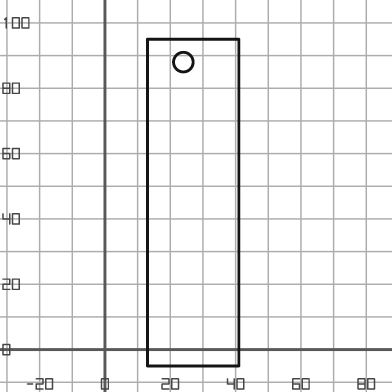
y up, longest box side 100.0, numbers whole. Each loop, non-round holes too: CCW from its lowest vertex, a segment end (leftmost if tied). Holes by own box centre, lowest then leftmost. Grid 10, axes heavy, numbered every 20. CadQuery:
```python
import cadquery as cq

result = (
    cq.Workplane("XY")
    .moveTo(13.0, -5.0)
    .lineTo(41.0, -5.0)
    .lineTo(41.0, 95.0)
    .lineTo(13.0, 95.0)
    .close()
    .moveTo(24.0, 88.0)
    .circle(3.0)
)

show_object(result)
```